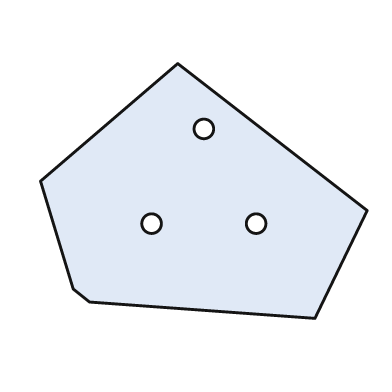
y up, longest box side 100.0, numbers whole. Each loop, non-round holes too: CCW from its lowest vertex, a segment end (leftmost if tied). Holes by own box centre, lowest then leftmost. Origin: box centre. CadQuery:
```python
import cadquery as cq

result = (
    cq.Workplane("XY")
    .moveTo(34.0, -39.0)
    .lineTo(50.0, -6.0)
    .lineTo(-8.0, 39.0)
    .lineTo(-50.0, 3.0)
    .lineTo(-40.0, -30.0)
    .lineTo(-35.0, -34.0)
    .close()
    .moveTo(-16.0, -10.0)
    .circle(3.0)
    .moveTo(16.0, -10.0)
    .circle(3.0)
    .moveTo(0.0, 19.0)
    .circle(3.0)
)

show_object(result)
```